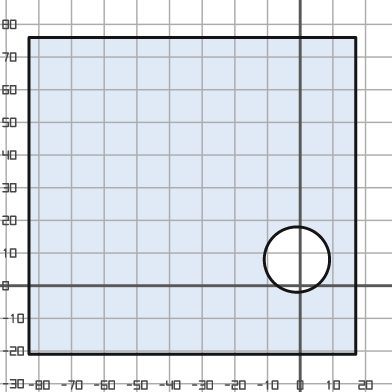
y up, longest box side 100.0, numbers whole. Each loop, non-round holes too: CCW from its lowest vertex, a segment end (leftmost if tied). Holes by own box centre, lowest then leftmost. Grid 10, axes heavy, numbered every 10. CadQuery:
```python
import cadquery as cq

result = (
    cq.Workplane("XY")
    .moveTo(-83.0, -21.0)
    .lineTo(17.0, -21.0)
    .lineTo(17.0, 76.0)
    .lineTo(-83.0, 76.0)
    .close()
    .moveTo(-1.0, 8.0)
    .circle(10.0)
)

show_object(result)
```